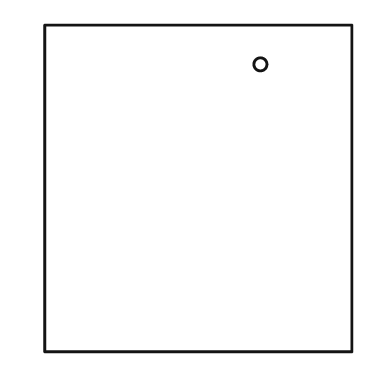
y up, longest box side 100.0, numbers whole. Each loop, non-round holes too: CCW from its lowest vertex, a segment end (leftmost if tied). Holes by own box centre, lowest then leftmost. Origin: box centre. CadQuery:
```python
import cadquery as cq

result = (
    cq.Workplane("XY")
    .moveTo(-47.0, -50.0)
    .lineTo(47.0, -50.0)
    .lineTo(47.0, 50.0)
    .lineTo(-47.0, 50.0)
    .close()
    .moveTo(19.0, 38.0)
    .circle(2.0)
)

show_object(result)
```